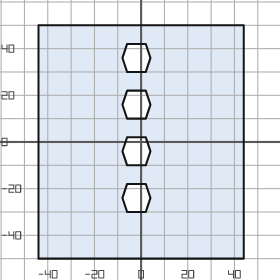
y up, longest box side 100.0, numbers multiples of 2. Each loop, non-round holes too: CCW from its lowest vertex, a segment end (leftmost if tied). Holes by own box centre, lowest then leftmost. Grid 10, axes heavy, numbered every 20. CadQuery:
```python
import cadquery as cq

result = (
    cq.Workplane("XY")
    .moveTo(-44.0, -50.0)
    .lineTo(44.0, -50.0)
    .lineTo(44.0, 50.0)
    .lineTo(-44.0, 50.0)
    .close()
    .moveTo(-6.0, -30.0)
    .lineTo(2.0, -30.0)
    .lineTo(4.0, -24.0)
    .lineTo(2.0, -18.0)
    .lineTo(-6.0, -18.0)
    .lineTo(-8.0, -24.0)
    .close()
    .moveTo(-6.0, -10.0)
    .lineTo(2.0, -10.0)
    .lineTo(4.0, -4.0)
    .lineTo(2.0, 2.0)
    .lineTo(-6.0, 2.0)
    .lineTo(-8.0, -4.0)
    .close()
    .moveTo(-6.0, 10.0)
    .lineTo(2.0, 10.0)
    .lineTo(4.0, 16.0)
    .lineTo(2.0, 22.0)
    .lineTo(-6.0, 22.0)
    .lineTo(-8.0, 16.0)
    .close()
    .moveTo(-6.0, 30.0)
    .lineTo(2.0, 30.0)
    .lineTo(4.0, 36.0)
    .lineTo(2.0, 42.0)
    .lineTo(-6.0, 42.0)
    .lineTo(-8.0, 36.0)
    .close()
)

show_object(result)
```